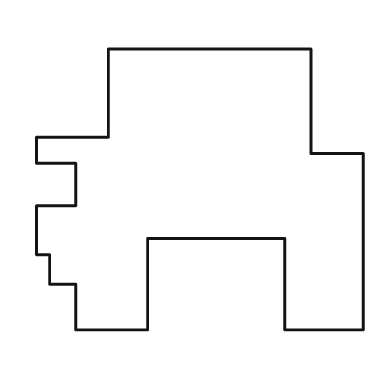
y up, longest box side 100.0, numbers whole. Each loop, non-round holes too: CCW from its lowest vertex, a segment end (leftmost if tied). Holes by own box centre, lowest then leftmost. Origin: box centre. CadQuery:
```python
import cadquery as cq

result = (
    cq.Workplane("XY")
    .moveTo(-38.0, -43.0)
    .lineTo(-16.0, -43.0)
    .lineTo(-16.0, -15.0)
    .lineTo(26.0, -15.0)
    .lineTo(26.0, -43.0)
    .lineTo(50.0, -43.0)
    .lineTo(50.0, 11.0)
    .lineTo(34.0, 11.0)
    .lineTo(34.0, 43.0)
    .lineTo(-28.0, 43.0)
    .lineTo(-28.0, 16.0)
    .lineTo(-50.0, 16.0)
    .lineTo(-50.0, 8.0)
    .lineTo(-38.0, 8.0)
    .lineTo(-38.0, -5.0)
    .lineTo(-50.0, -5.0)
    .lineTo(-50.0, -20.0)
    .lineTo(-46.0, -20.0)
    .lineTo(-46.0, -29.0)
    .lineTo(-38.0, -29.0)
    .close()
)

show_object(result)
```